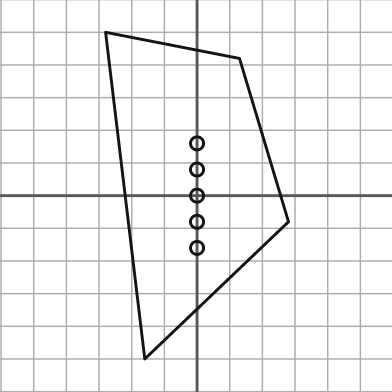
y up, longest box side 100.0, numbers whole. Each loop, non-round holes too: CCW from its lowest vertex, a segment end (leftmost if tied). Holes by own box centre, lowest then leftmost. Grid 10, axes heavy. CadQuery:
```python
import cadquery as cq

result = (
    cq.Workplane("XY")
    .moveTo(-16.0, -50.0)
    .lineTo(28.0, -8.0)
    .lineTo(13.0, 42.0)
    .lineTo(-28.0, 50.0)
    .close()
    .moveTo(0.0, -16.0)
    .circle(2.0)
    .moveTo(0.0, -8.0)
    .circle(2.0)
    .moveTo(0.0, 0.0)
    .circle(2.0)
    .moveTo(0.0, 8.0)
    .circle(2.0)
    .moveTo(0.0, 16.0)
    .circle(2.0)
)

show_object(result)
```